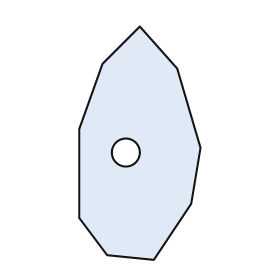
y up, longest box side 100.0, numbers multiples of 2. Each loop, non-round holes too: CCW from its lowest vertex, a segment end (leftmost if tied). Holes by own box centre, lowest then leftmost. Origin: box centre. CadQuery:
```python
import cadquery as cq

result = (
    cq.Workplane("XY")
    .moveTo(6.0, -50.0)
    .lineTo(22.0, -26.0)
    .lineTo(26.0, -2.0)
    .lineTo(16.0, 32.0)
    .lineTo(0.0, 50.0)
    .lineTo(-16.0, 34.0)
    .lineTo(-26.0, 6.0)
    .lineTo(-26.0, -32.0)
    .lineTo(-14.0, -48.0)
    .close()
    .moveTo(-6.0, -4.0)
    .circle(6.0)
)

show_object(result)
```